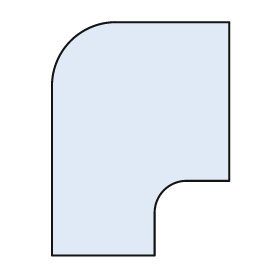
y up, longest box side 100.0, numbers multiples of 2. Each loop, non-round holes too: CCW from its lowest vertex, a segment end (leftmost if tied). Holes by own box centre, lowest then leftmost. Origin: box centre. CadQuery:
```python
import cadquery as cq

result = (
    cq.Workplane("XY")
    .moveTo(-38.0, -50.0)
    .lineTo(6.0, -50.0)
    .lineTo(6.0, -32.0)
    .threePointArc((10.0, -22.0), (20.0, -18.0))
    .lineTo(38.0, -18.0)
    .lineTo(38.0, 50.0)
    .lineTo(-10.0, 50.0)
    .threePointArc((-30.0, 42.0), (-38.0, 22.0))
    .close()
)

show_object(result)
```